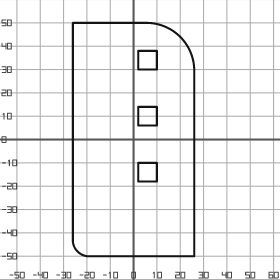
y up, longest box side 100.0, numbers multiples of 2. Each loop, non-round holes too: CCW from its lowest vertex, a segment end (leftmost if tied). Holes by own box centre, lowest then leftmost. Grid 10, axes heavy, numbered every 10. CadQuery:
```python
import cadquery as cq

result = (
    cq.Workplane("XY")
    .moveTo(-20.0, -50.0)
    .lineTo(26.0, -50.0)
    .lineTo(26.0, 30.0)
    .threePointArc((20.0, 44.0), (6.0, 50.0))
    .lineTo(-26.0, 50.0)
    .lineTo(-26.0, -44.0)
    .threePointArc((-24.0, -48.0), (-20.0, -50.0))
    .close()
    .moveTo(2.0, -18.0)
    .lineTo(10.0, -18.0)
    .lineTo(10.0, -10.0)
    .lineTo(2.0, -10.0)
    .close()
    .moveTo(2.0, 6.0)
    .lineTo(10.0, 6.0)
    .lineTo(10.0, 14.0)
    .lineTo(2.0, 14.0)
    .close()
    .moveTo(2.0, 30.0)
    .lineTo(10.0, 30.0)
    .lineTo(10.0, 38.0)
    .lineTo(2.0, 38.0)
    .close()
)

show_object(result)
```